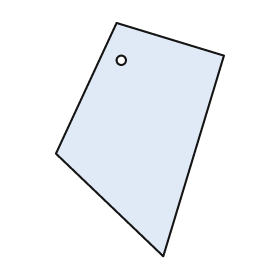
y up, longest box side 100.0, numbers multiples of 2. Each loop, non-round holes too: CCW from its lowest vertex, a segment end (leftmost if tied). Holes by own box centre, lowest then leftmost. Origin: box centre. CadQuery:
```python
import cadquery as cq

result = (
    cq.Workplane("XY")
    .moveTo(10.0, -50.0)
    .lineTo(36.0, 36.0)
    .lineTo(-10.0, 50.0)
    .lineTo(-36.0, -6.0)
    .close()
    .moveTo(-8.0, 34.0)
    .circle(2.0)
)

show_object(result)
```